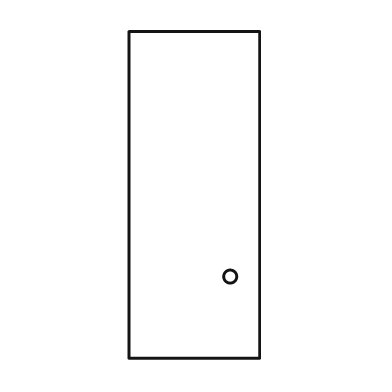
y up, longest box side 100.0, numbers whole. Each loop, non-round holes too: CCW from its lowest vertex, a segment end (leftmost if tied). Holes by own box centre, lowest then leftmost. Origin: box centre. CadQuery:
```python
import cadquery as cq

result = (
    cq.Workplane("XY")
    .moveTo(-20.0, -50.0)
    .lineTo(20.0, -50.0)
    .lineTo(20.0, 50.0)
    .lineTo(-20.0, 50.0)
    .close()
    .moveTo(11.0, -25.0)
    .circle(2.0)
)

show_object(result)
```